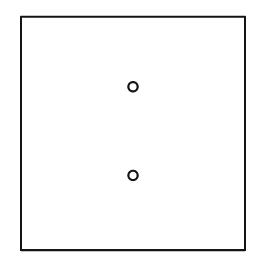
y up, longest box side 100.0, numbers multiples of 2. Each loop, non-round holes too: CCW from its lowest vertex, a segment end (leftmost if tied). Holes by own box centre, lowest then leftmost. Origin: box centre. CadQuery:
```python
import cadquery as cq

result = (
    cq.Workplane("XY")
    .moveTo(-48.0, -50.0)
    .lineTo(48.0, -50.0)
    .lineTo(48.0, 50.0)
    .lineTo(-48.0, 50.0)
    .close()
    .moveTo(0.0, -18.0)
    .circle(2.0)
    .moveTo(0.0, 20.0)
    .circle(2.0)
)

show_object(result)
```